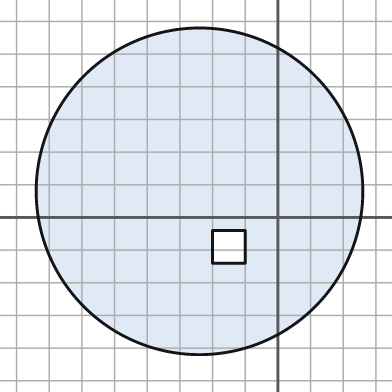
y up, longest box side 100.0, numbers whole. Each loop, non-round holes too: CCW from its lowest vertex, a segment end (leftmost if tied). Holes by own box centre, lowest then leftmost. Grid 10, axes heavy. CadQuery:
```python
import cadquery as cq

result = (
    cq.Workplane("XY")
    .moveTo(-24.0, 8.0)
    .circle(50.0)
    .moveTo(-20.0, -14.0)
    .lineTo(-10.0, -14.0)
    .lineTo(-10.0, -4.0)
    .lineTo(-20.0, -4.0)
    .close()
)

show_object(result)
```